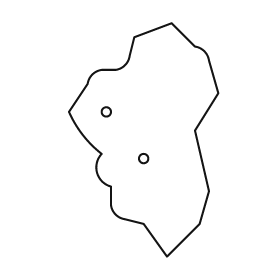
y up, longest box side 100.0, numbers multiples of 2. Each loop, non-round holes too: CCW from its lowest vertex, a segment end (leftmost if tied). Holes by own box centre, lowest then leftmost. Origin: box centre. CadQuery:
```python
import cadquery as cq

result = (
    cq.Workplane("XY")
    .moveTo(10.0, -50.0)
    .lineTo(24.0, -36.0)
    .lineTo(28.0, -22.0)
    .lineTo(22.0, 4.0)
    .lineTo(32.0, 20.0)
    .lineTo(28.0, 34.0)
    .threePointArc((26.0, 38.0), (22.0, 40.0))
    .lineTo(12.0, 50.0)
    .lineTo(-4.0, 44.0)
    .lineTo(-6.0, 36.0)
    .threePointArc((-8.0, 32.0), (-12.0, 30.0))
    .lineTo(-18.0, 30.0)
    .threePointArc((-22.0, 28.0), (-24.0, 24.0))
    .lineTo(-32.0, 12.0)
    .threePointArc((-26.0, 2.0), (-18.0, -6.0))
    .threePointArc((-20.0, -14.0), (-14.0, -20.0))
    .lineTo(-14.0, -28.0)
    .threePointArc((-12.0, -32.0), (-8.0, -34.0))
    .lineTo(0.0, -36.0)
    .close()
    .moveTo(0.0, -8.0)
    .circle(2.0)
    .moveTo(-16.0, 12.0)
    .circle(2.0)
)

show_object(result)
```